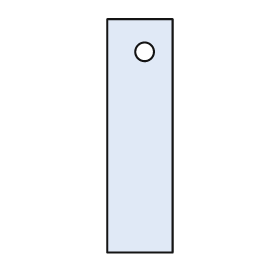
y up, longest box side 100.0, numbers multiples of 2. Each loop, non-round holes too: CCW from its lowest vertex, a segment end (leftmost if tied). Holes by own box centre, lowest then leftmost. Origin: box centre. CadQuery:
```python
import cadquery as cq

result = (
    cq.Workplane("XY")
    .moveTo(-14.0, -50.0)
    .lineTo(14.0, -50.0)
    .lineTo(14.0, 50.0)
    .lineTo(-14.0, 50.0)
    .close()
    .moveTo(2.0, 36.0)
    .circle(4.0)
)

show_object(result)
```